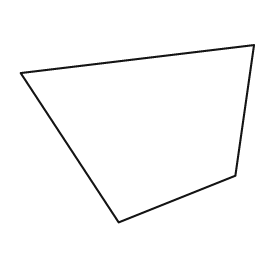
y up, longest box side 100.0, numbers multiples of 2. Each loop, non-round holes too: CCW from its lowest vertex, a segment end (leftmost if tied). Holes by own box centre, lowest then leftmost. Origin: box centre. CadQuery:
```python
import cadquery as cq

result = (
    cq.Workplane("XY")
    .moveTo(-8.0, -38.0)
    .lineTo(42.0, -18.0)
    .lineTo(50.0, 38.0)
    .lineTo(-50.0, 26.0)
    .close()
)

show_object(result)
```